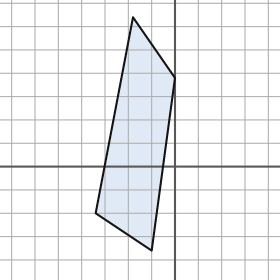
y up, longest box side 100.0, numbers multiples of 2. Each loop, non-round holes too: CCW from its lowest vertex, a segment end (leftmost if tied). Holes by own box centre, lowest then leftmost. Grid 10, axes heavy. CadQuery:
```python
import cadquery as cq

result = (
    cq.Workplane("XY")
    .moveTo(-10.0, -36.0)
    .lineTo(0.0, 38.0)
    .lineTo(-18.0, 64.0)
    .lineTo(-34.0, -20.0)
    .close()
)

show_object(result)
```